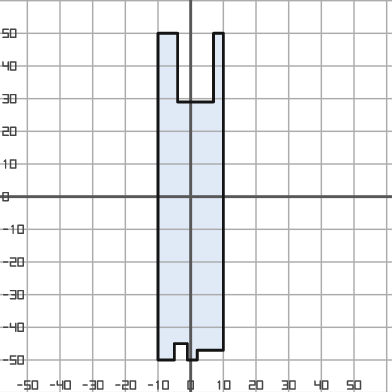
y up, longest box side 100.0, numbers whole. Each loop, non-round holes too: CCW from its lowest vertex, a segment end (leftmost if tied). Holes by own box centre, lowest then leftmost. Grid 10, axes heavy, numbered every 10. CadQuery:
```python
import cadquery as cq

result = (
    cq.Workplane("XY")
    .moveTo(-10.0, -50.0)
    .lineTo(-5.0, -50.0)
    .lineTo(-5.0, -45.0)
    .lineTo(-1.0, -45.0)
    .lineTo(-1.0, -50.0)
    .lineTo(2.0, -50.0)
    .lineTo(2.0, -47.0)
    .lineTo(10.0, -47.0)
    .lineTo(10.0, 50.0)
    .lineTo(7.0, 50.0)
    .lineTo(7.0, 29.0)
    .lineTo(-4.0, 29.0)
    .lineTo(-4.0, 50.0)
    .lineTo(-10.0, 50.0)
    .close()
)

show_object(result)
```